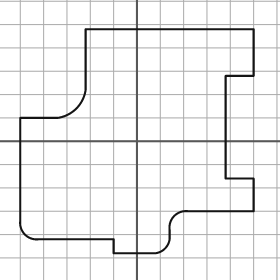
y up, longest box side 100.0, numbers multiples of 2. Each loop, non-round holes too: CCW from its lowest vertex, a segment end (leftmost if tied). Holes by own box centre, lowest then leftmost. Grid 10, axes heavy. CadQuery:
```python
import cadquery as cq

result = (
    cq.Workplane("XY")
    .moveTo(-10.0, -48.0)
    .lineTo(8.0, -48.0)
    .threePointArc((12.0, -46.0), (14.0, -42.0))
    .lineTo(14.0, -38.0)
    .threePointArc((16.0, -32.0), (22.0, -30.0))
    .lineTo(50.0, -30.0)
    .lineTo(50.0, -16.0)
    .lineTo(38.0, -16.0)
    .lineTo(38.0, 28.0)
    .lineTo(50.0, 28.0)
    .lineTo(50.0, 48.0)
    .lineTo(-22.0, 48.0)
    .lineTo(-22.0, 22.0)
    .threePointArc((-26.0, 14.0), (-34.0, 10.0))
    .lineTo(-50.0, 10.0)
    .lineTo(-50.0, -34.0)
    .threePointArc((-48.0, -40.0), (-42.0, -42.0))
    .lineTo(-10.0, -42.0)
    .close()
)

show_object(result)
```